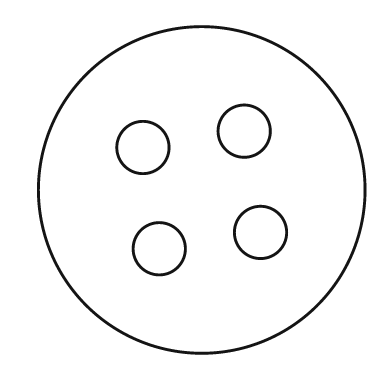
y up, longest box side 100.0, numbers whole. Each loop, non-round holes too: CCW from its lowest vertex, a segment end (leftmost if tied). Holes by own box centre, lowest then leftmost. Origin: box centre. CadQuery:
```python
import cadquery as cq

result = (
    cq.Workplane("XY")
    .moveTo(0.0, 0.0)
    .circle(50.0)
    .moveTo(-13.0, -18.0)
    .circle(8.0)
    .moveTo(18.0, -13.0)
    .circle(8.0)
    .moveTo(-18.0, 13.0)
    .circle(8.0)
    .moveTo(13.0, 18.0)
    .circle(8.0)
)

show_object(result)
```